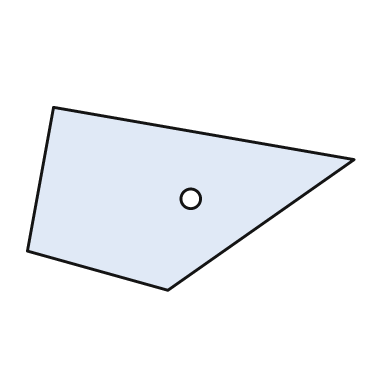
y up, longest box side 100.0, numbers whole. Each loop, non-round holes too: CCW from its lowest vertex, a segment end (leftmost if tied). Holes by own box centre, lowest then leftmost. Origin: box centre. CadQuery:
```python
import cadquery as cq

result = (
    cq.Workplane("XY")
    .moveTo(-7.0, -28.0)
    .lineTo(50.0, 12.0)
    .lineTo(-42.0, 28.0)
    .lineTo(-50.0, -16.0)
    .close()
    .moveTo(0.0, 0.0)
    .circle(3.0)
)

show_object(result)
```